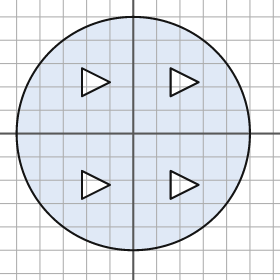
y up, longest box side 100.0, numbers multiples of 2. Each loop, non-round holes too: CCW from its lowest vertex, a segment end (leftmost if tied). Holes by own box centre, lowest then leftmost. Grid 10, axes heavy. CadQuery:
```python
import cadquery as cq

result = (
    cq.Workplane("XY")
    .moveTo(0.0, 0.0)
    .circle(50.0)
    .moveTo(-22.0, -28.0)
    .lineTo(-10.0, -22.0)
    .lineTo(-22.0, -16.0)
    .close()
    .moveTo(16.0, -28.0)
    .lineTo(28.0, -22.0)
    .lineTo(16.0, -16.0)
    .close()
    .moveTo(-22.0, 16.0)
    .lineTo(-10.0, 22.0)
    .lineTo(-22.0, 28.0)
    .close()
    .moveTo(16.0, 16.0)
    .lineTo(28.0, 22.0)
    .lineTo(16.0, 28.0)
    .close()
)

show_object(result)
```